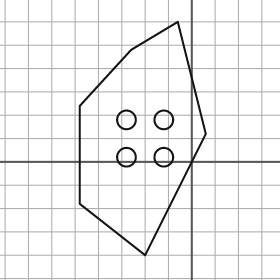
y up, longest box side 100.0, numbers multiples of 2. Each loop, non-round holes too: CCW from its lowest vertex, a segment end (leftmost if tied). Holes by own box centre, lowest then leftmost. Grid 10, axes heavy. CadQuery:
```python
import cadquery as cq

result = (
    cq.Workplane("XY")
    .moveTo(-20.0, -40.0)
    .lineTo(6.0, 12.0)
    .lineTo(-6.0, 60.0)
    .lineTo(-26.0, 48.0)
    .lineTo(-48.0, 24.0)
    .lineTo(-48.0, -18.0)
    .close()
    .moveTo(-28.0, 2.0)
    .circle(4.0)
    .moveTo(-12.0, 2.0)
    .circle(4.0)
    .moveTo(-28.0, 18.0)
    .circle(4.0)
    .moveTo(-12.0, 18.0)
    .circle(4.0)
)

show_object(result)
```